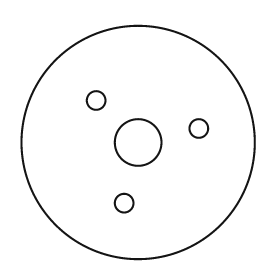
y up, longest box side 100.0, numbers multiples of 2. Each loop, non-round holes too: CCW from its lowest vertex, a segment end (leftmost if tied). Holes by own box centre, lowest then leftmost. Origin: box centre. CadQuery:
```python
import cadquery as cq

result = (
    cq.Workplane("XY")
    .moveTo(0.0, 0.0)
    .circle(50.0)
    .moveTo(-6.0, -26.0)
    .circle(4.0)
    .moveTo(0.0, 0.0)
    .circle(10.0)
    .moveTo(26.0, 6.0)
    .circle(4.0)
    .moveTo(-18.0, 18.0)
    .circle(4.0)
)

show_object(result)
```